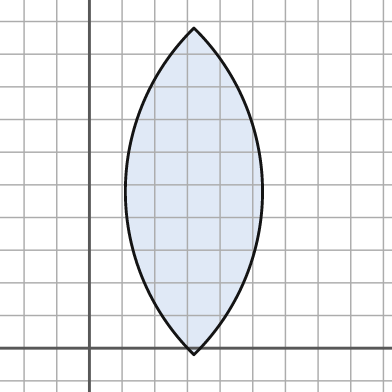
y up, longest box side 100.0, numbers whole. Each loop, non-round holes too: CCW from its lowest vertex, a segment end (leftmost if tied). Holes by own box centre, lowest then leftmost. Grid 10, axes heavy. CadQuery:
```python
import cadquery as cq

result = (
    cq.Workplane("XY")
    .moveTo(32.0, -2.0)
    .threePointArc((53.0, 48.0), (32.0, 98.0))
    .threePointArc((11.0, 48.0), (32.0, -2.0))
    .close()
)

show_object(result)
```